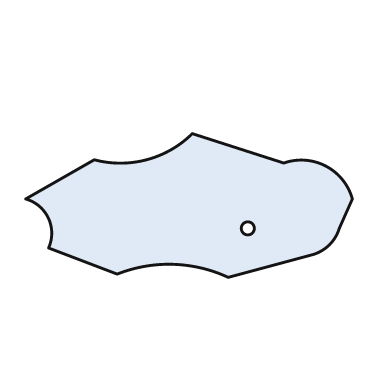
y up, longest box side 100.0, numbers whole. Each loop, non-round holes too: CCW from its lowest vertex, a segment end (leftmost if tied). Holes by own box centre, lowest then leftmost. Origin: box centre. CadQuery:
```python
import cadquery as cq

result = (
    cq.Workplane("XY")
    .moveTo(12.0, -22.0)
    .lineTo(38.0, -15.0)
    .threePointArc((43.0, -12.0), (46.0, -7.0))
    .lineTo(50.0, 2.0)
    .threePointArc((42.0, 12.0), (29.0, 13.0))
    .lineTo(1.0, 22.0)
    .threePointArc((-13.0, 14.0), (-29.0, 14.0))
    .lineTo(-50.0, 2.0)
    .threePointArc((-43.0, -4.0), (-43.0, -13.0))
    .lineTo(-22.0, -21.0)
    .threePointArc((-5.0, -18.0), (12.0, -22.0))
    .close()
    .moveTo(18.0, -7.0)
    .circle(2.0)
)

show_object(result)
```